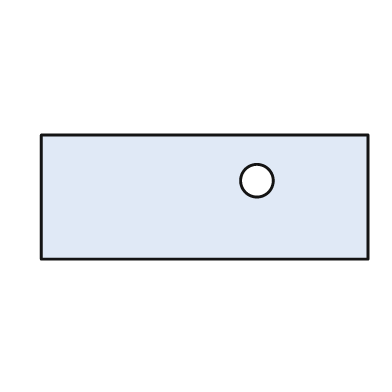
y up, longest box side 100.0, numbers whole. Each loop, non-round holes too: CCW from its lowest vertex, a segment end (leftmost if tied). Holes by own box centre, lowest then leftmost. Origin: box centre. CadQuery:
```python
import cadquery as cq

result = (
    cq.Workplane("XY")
    .moveTo(-50.0, -19.0)
    .lineTo(50.0, -19.0)
    .lineTo(50.0, 19.0)
    .lineTo(-50.0, 19.0)
    .close()
    .moveTo(16.0, 5.0)
    .circle(5.0)
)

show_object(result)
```